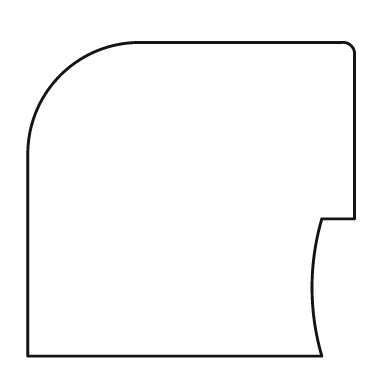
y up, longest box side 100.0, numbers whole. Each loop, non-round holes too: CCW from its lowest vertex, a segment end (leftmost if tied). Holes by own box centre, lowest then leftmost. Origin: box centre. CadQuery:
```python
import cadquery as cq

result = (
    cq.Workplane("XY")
    .moveTo(-50.0, -48.0)
    .lineTo(40.0, -48.0)
    .threePointArc((37.0, -27.0), (40.0, -6.0))
    .lineTo(50.0, -6.0)
    .lineTo(50.0, 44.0)
    .threePointArc((49.0, 47.0), (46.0, 48.0))
    .lineTo(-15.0, 48.0)
    .threePointArc((-40.0, 38.0), (-50.0, 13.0))
    .close()
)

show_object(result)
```